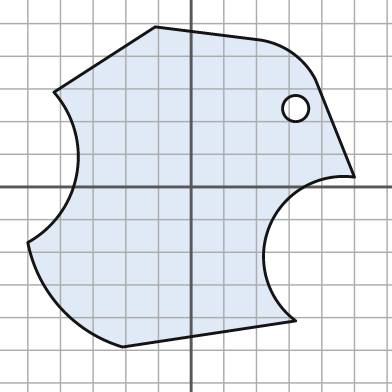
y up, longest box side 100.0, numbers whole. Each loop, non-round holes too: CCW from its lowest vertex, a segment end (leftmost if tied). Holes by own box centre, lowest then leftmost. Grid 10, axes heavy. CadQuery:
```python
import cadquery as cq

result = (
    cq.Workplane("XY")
    .moveTo(-21.0, -49.0)
    .lineTo(32.0, -41.0)
    .threePointArc((24.0, -12.0), (50.0, 3.0))
    .lineTo(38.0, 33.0)
    .threePointArc((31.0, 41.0), (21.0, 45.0))
    .lineTo(-11.0, 49.0)
    .lineTo(-42.0, 29.0)
    .threePointArc((-35.0, 4.0), (-50.0, -17.0))
    .threePointArc((-40.0, -37.0), (-21.0, -49.0))
    .close()
    .moveTo(32.0, 24.0)
    .circle(4.0)
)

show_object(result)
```